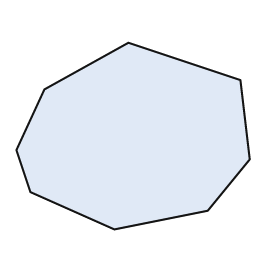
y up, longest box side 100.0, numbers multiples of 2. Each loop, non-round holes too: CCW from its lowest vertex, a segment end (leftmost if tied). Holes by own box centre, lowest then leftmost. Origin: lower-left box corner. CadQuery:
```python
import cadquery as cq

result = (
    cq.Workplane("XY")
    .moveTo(42.0, 0.0)
    .lineTo(82.0, 8.0)
    .lineTo(100.0, 30.0)
    .lineTo(96.0, 64.0)
    .lineTo(48.0, 80.0)
    .lineTo(12.0, 60.0)
    .lineTo(0.0, 34.0)
    .lineTo(6.0, 16.0)
    .close()
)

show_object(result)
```